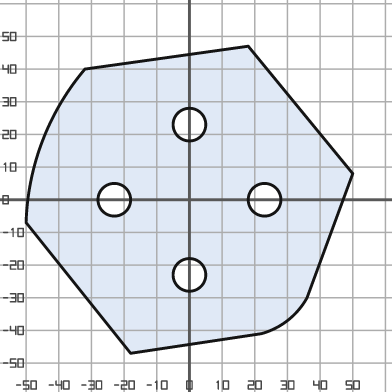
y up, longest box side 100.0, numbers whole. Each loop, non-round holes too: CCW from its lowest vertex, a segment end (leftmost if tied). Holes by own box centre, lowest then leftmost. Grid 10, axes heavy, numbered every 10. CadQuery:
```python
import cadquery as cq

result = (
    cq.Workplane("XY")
    .moveTo(-18.0, -47.0)
    .lineTo(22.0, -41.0)
    .threePointArc((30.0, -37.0), (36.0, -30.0))
    .lineTo(50.0, 8.0)
    .lineTo(18.0, 47.0)
    .lineTo(-32.0, 40.0)
    .threePointArc((-45.0, 18.0), (-50.0, -7.0))
    .close()
    .moveTo(0.0, -23.0)
    .circle(5.0)
    .moveTo(-23.0, 0.0)
    .circle(5.0)
    .moveTo(23.0, 0.0)
    .circle(5.0)
    .moveTo(0.0, 23.0)
    .circle(5.0)
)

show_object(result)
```